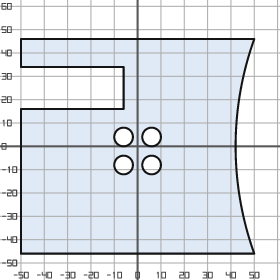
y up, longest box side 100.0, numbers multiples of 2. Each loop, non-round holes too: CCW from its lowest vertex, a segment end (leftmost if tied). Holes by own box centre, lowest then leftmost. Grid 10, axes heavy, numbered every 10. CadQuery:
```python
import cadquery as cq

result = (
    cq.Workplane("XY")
    .moveTo(-50.0, -46.0)
    .lineTo(50.0, -46.0)
    .threePointArc((42.0, 0.0), (50.0, 46.0))
    .lineTo(-50.0, 46.0)
    .lineTo(-50.0, 34.0)
    .lineTo(-6.0, 34.0)
    .lineTo(-6.0, 16.0)
    .lineTo(-50.0, 16.0)
    .close()
    .moveTo(-6.0, -8.0)
    .circle(4.0)
    .moveTo(6.0, -8.0)
    .circle(4.0)
    .moveTo(-6.0, 4.0)
    .circle(4.0)
    .moveTo(6.0, 4.0)
    .circle(4.0)
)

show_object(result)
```